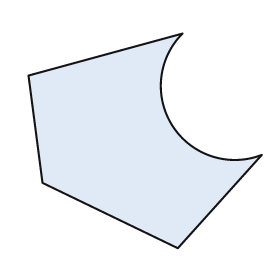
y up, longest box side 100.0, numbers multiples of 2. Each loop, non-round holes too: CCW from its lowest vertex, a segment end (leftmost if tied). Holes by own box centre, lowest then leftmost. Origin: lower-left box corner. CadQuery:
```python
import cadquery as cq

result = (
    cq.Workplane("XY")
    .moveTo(64.0, 0.0)
    .lineTo(100.0, 40.0)
    .threePointArc((62.0, 52.0), (66.0, 92.0))
    .lineTo(0.0, 74.0)
    .lineTo(6.0, 28.0)
    .close()
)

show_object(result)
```